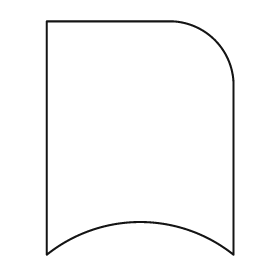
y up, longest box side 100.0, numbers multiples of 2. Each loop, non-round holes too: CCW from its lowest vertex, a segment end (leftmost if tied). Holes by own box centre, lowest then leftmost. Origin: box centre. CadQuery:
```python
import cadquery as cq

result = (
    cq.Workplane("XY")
    .moveTo(-40.0, -50.0)
    .threePointArc((0.0, -36.0), (40.0, -50.0))
    .lineTo(40.0, 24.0)
    .threePointArc((32.0, 42.0), (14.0, 50.0))
    .lineTo(-40.0, 50.0)
    .close()
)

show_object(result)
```